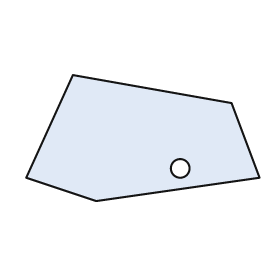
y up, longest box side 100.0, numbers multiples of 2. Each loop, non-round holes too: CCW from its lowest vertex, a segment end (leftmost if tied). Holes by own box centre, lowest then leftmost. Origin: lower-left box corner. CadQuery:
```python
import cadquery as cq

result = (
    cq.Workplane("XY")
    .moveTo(30.0, 0.0)
    .lineTo(100.0, 10.0)
    .lineTo(88.0, 42.0)
    .lineTo(20.0, 54.0)
    .lineTo(0.0, 10.0)
    .close()
    .moveTo(66.0, 14.0)
    .circle(4.0)
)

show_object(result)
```